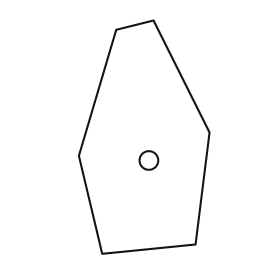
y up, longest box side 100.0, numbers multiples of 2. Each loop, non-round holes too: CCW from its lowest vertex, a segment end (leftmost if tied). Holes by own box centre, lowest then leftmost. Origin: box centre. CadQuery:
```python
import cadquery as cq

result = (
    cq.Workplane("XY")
    .moveTo(-18.0, -50.0)
    .lineTo(22.0, -46.0)
    .lineTo(28.0, 2.0)
    .lineTo(4.0, 50.0)
    .lineTo(-12.0, 46.0)
    .lineTo(-28.0, -8.0)
    .close()
    .moveTo(2.0, -10.0)
    .circle(4.0)
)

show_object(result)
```